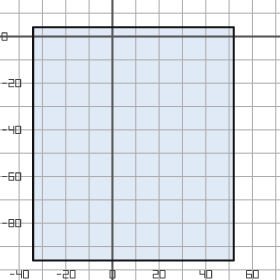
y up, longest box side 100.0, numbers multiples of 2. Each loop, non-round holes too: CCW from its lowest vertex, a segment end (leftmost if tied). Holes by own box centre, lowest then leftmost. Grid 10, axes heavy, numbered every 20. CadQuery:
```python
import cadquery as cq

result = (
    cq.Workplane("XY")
    .moveTo(-34.0, -96.0)
    .lineTo(52.0, -96.0)
    .lineTo(52.0, 4.0)
    .lineTo(-34.0, 4.0)
    .close()
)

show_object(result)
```